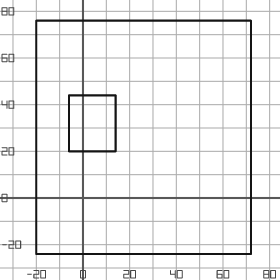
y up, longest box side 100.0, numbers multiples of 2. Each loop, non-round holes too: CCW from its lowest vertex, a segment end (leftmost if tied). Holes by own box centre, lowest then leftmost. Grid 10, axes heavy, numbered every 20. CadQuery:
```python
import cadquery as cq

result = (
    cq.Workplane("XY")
    .moveTo(-20.0, -24.0)
    .lineTo(72.0, -24.0)
    .lineTo(72.0, 76.0)
    .lineTo(-20.0, 76.0)
    .close()
    .moveTo(-6.0, 20.0)
    .lineTo(14.0, 20.0)
    .lineTo(14.0, 44.0)
    .lineTo(-6.0, 44.0)
    .close()
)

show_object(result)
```